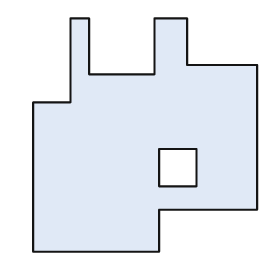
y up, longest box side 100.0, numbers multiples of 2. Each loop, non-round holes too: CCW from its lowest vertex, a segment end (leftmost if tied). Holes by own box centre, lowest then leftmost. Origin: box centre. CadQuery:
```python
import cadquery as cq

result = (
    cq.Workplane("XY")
    .moveTo(-48.0, -50.0)
    .lineTo(6.0, -50.0)
    .lineTo(6.0, -32.0)
    .lineTo(48.0, -32.0)
    .lineTo(48.0, 30.0)
    .lineTo(18.0, 30.0)
    .lineTo(18.0, 50.0)
    .lineTo(4.0, 50.0)
    .lineTo(4.0, 26.0)
    .lineTo(-24.0, 26.0)
    .lineTo(-24.0, 50.0)
    .lineTo(-32.0, 50.0)
    .lineTo(-32.0, 14.0)
    .lineTo(-48.0, 14.0)
    .close()
    .moveTo(6.0, -22.0)
    .lineTo(22.0, -22.0)
    .lineTo(22.0, -6.0)
    .lineTo(6.0, -6.0)
    .close()
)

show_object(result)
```